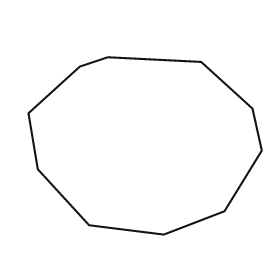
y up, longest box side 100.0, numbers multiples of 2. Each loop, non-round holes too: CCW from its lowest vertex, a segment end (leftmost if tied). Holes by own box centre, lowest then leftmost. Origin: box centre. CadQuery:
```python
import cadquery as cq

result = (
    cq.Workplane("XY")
    .moveTo(8.0, -38.0)
    .lineTo(34.0, -28.0)
    .lineTo(50.0, -2.0)
    .lineTo(46.0, 16.0)
    .lineTo(24.0, 36.0)
    .lineTo(-16.0, 38.0)
    .lineTo(-28.0, 34.0)
    .lineTo(-50.0, 14.0)
    .lineTo(-46.0, -10.0)
    .lineTo(-24.0, -34.0)
    .close()
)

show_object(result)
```